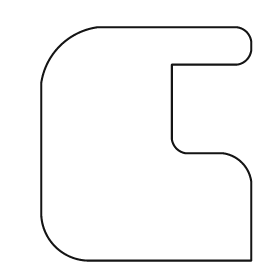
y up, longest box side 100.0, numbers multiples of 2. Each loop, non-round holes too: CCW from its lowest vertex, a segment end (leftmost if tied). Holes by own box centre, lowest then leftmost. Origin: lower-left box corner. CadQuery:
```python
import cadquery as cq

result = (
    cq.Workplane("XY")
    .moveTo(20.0, 0.0)
    .lineTo(90.0, 0.0)
    .lineTo(90.0, 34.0)
    .threePointArc((86.0, 42.0), (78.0, 46.0))
    .lineTo(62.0, 46.0)
    .threePointArc((58.0, 48.0), (56.0, 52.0))
    .lineTo(56.0, 84.0)
    .lineTo(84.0, 84.0)
    .threePointArc((88.0, 86.0), (90.0, 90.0))
    .lineTo(90.0, 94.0)
    .threePointArc((88.0, 98.0), (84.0, 100.0))
    .lineTo(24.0, 100.0)
    .threePointArc((8.0, 92.0), (0.0, 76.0))
    .lineTo(0.0, 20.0)
    .threePointArc((6.0, 6.0), (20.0, 0.0))
    .close()
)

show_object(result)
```